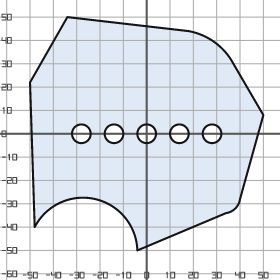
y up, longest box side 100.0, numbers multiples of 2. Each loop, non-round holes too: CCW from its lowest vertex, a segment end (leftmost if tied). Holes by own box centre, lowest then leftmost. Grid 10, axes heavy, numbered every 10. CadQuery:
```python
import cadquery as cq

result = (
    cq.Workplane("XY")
    .moveTo(-4.0, -50.0)
    .lineTo(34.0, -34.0)
    .threePointArc((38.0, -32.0), (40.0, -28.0))
    .lineTo(50.0, 8.0)
    .lineTo(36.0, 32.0)
    .threePointArc((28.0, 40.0), (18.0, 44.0))
    .lineTo(-34.0, 50.0)
    .lineTo(-50.0, 22.0)
    .lineTo(-48.0, -40.0)
    .threePointArc((-22.0, -28.0), (-4.0, -50.0))
    .close()
    .moveTo(-28.0, 0.0)
    .circle(4.0)
    .moveTo(-14.0, 0.0)
    .circle(4.0)
    .moveTo(0.0, 0.0)
    .circle(4.0)
    .moveTo(14.0, 0.0)
    .circle(4.0)
    .moveTo(28.0, 0.0)
    .circle(4.0)
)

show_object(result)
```